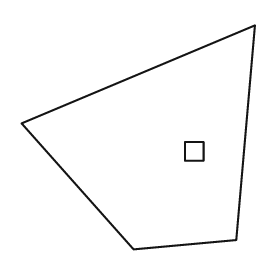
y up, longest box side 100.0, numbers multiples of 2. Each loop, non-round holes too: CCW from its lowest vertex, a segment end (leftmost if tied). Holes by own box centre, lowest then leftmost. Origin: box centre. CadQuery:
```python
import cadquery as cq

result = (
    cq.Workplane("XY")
    .moveTo(-2.0, -48.0)
    .lineTo(42.0, -44.0)
    .lineTo(50.0, 48.0)
    .lineTo(-50.0, 6.0)
    .close()
    .moveTo(20.0, -10.0)
    .lineTo(28.0, -10.0)
    .lineTo(28.0, -2.0)
    .lineTo(20.0, -2.0)
    .close()
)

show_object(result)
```